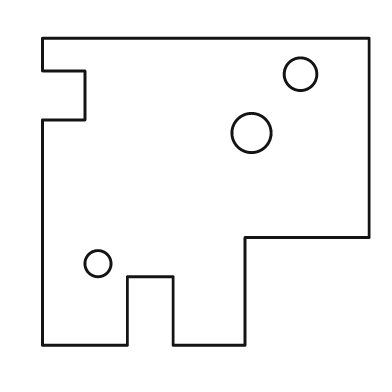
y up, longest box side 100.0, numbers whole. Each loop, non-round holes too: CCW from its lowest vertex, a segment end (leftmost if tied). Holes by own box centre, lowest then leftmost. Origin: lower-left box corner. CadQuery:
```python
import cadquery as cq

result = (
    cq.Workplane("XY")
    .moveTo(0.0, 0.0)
    .lineTo(26.0, 0.0)
    .lineTo(26.0, 21.0)
    .lineTo(40.0, 21.0)
    .lineTo(40.0, 0.0)
    .lineTo(62.0, 0.0)
    .lineTo(62.0, 33.0)
    .lineTo(100.0, 33.0)
    .lineTo(100.0, 94.0)
    .lineTo(0.0, 94.0)
    .lineTo(0.0, 84.0)
    .lineTo(13.0, 84.0)
    .lineTo(13.0, 69.0)
    .lineTo(0.0, 69.0)
    .close()
    .moveTo(17.0, 25.0)
    .circle(4.0)
    .moveTo(64.0, 65.0)
    .circle(6.0)
    .moveTo(79.0, 83.0)
    .circle(5.0)
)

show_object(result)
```